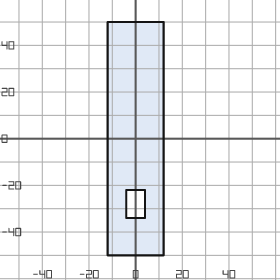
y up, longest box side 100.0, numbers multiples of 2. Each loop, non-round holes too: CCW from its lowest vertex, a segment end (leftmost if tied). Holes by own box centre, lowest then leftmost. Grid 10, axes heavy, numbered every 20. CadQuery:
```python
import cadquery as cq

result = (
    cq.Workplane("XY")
    .moveTo(-12.0, -50.0)
    .lineTo(12.0, -50.0)
    .lineTo(12.0, 50.0)
    .lineTo(-12.0, 50.0)
    .close()
    .moveTo(-4.0, -34.0)
    .lineTo(4.0, -34.0)
    .lineTo(4.0, -22.0)
    .lineTo(-4.0, -22.0)
    .close()
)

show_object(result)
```